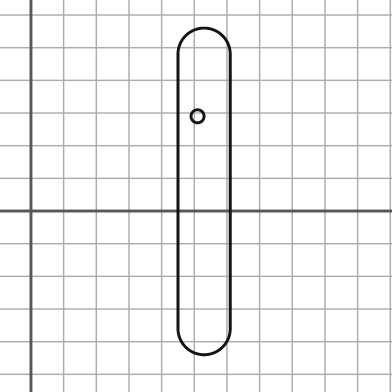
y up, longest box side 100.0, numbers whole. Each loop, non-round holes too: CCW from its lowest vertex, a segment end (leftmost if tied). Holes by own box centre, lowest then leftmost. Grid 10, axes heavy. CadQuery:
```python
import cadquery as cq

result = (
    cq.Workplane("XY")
    .moveTo(45.0, -36.0)
    .threePointArc((53.0, -44.0), (61.0, -36.0))
    .lineTo(61.0, 48.0)
    .threePointArc((53.0, 56.0), (45.0, 48.0))
    .close()
    .moveTo(51.0, 29.0)
    .circle(2.0)
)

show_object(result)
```